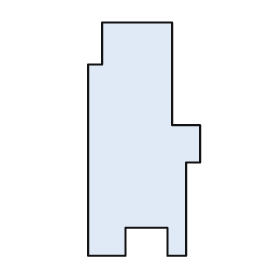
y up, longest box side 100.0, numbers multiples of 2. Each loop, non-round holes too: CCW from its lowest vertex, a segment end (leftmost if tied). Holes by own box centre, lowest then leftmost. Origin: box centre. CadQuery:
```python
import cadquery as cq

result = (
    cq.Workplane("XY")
    .moveTo(-24.0, -50.0)
    .lineTo(-8.0, -50.0)
    .lineTo(-8.0, -38.0)
    .lineTo(10.0, -38.0)
    .lineTo(10.0, -50.0)
    .lineTo(18.0, -50.0)
    .lineTo(18.0, -10.0)
    .lineTo(24.0, -10.0)
    .lineTo(24.0, 6.0)
    .lineTo(12.0, 6.0)
    .lineTo(12.0, 50.0)
    .lineTo(-18.0, 50.0)
    .lineTo(-18.0, 32.0)
    .lineTo(-24.0, 32.0)
    .close()
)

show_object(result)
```